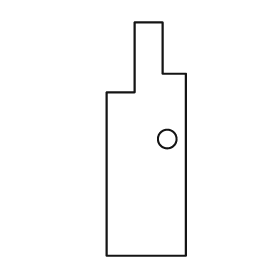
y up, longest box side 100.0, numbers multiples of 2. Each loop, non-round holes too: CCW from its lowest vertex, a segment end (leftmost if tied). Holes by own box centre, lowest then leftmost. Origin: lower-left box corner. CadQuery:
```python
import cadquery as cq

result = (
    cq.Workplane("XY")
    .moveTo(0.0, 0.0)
    .lineTo(34.0, 0.0)
    .lineTo(34.0, 78.0)
    .lineTo(24.0, 78.0)
    .lineTo(24.0, 100.0)
    .lineTo(12.0, 100.0)
    .lineTo(12.0, 70.0)
    .lineTo(0.0, 70.0)
    .close()
    .moveTo(26.0, 50.0)
    .circle(4.0)
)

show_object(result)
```